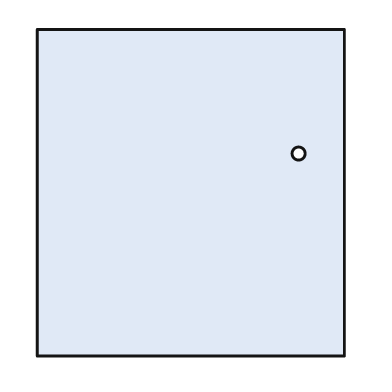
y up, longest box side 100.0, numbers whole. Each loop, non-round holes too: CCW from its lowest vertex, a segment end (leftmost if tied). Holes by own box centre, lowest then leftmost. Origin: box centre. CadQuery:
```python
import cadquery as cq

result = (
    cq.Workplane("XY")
    .moveTo(-47.0, -50.0)
    .lineTo(47.0, -50.0)
    .lineTo(47.0, 50.0)
    .lineTo(-47.0, 50.0)
    .close()
    .moveTo(33.0, 12.0)
    .circle(2.0)
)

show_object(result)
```